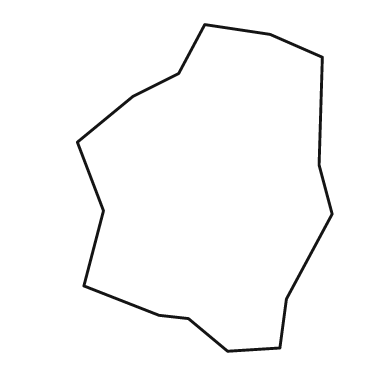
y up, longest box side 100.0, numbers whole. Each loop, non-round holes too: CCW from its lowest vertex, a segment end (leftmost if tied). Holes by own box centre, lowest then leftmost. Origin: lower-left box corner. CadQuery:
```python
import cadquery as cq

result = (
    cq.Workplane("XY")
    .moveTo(46.0, 0.0)
    .lineTo(62.0, 1.0)
    .lineTo(64.0, 16.0)
    .lineTo(78.0, 42.0)
    .lineTo(74.0, 57.0)
    .lineTo(75.0, 90.0)
    .lineTo(59.0, 97.0)
    .lineTo(39.0, 100.0)
    .lineTo(31.0, 85.0)
    .lineTo(17.0, 78.0)
    .lineTo(0.0, 64.0)
    .lineTo(8.0, 43.0)
    .lineTo(2.0, 20.0)
    .lineTo(25.0, 11.0)
    .lineTo(34.0, 10.0)
    .close()
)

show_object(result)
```